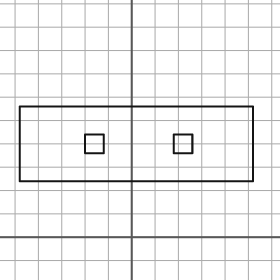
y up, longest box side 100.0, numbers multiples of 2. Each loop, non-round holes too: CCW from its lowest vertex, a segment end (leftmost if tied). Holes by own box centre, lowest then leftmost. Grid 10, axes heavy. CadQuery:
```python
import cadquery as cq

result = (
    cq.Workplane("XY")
    .moveTo(-48.0, 24.0)
    .lineTo(52.0, 24.0)
    .lineTo(52.0, 56.0)
    .lineTo(-48.0, 56.0)
    .close()
    .moveTo(-20.0, 36.0)
    .lineTo(-12.0, 36.0)
    .lineTo(-12.0, 44.0)
    .lineTo(-20.0, 44.0)
    .close()
    .moveTo(18.0, 36.0)
    .lineTo(26.0, 36.0)
    .lineTo(26.0, 44.0)
    .lineTo(18.0, 44.0)
    .close()
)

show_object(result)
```